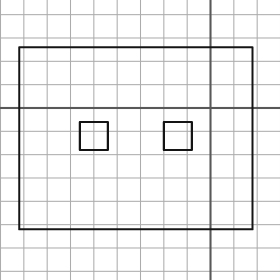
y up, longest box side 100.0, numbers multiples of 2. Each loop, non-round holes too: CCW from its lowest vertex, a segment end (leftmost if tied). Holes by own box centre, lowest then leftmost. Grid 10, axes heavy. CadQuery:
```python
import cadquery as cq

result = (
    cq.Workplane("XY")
    .moveTo(-82.0, -52.0)
    .lineTo(18.0, -52.0)
    .lineTo(18.0, 26.0)
    .lineTo(-82.0, 26.0)
    .close()
    .moveTo(-56.0, -18.0)
    .lineTo(-44.0, -18.0)
    .lineTo(-44.0, -6.0)
    .lineTo(-56.0, -6.0)
    .close()
    .moveTo(-20.0, -18.0)
    .lineTo(-8.0, -18.0)
    .lineTo(-8.0, -6.0)
    .lineTo(-20.0, -6.0)
    .close()
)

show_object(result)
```